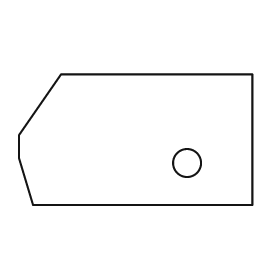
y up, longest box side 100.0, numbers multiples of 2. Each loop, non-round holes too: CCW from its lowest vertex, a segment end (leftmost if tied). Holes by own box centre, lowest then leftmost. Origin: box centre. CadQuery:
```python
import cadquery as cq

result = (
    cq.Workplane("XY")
    .moveTo(-44.0, -28.0)
    .lineTo(50.0, -28.0)
    .lineTo(50.0, 28.0)
    .lineTo(-32.0, 28.0)
    .lineTo(-50.0, 2.0)
    .lineTo(-50.0, -8.0)
    .close()
    .moveTo(22.0, -10.0)
    .circle(6.0)
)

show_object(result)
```